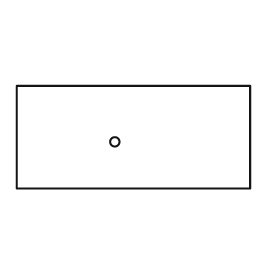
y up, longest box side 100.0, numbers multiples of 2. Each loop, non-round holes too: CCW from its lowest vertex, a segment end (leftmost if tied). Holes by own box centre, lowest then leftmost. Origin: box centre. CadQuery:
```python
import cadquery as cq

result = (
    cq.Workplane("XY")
    .moveTo(-50.0, -22.0)
    .lineTo(50.0, -22.0)
    .lineTo(50.0, 22.0)
    .lineTo(-50.0, 22.0)
    .close()
    .moveTo(-8.0, -2.0)
    .circle(2.0)
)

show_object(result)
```